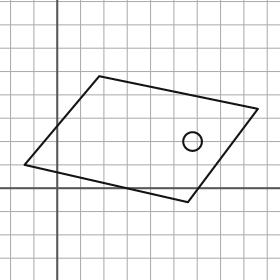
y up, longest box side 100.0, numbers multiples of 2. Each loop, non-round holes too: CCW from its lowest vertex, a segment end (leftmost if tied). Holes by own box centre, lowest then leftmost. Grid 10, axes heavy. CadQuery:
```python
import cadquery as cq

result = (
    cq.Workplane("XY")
    .moveTo(56.0, -6.0)
    .lineTo(86.0, 34.0)
    .lineTo(18.0, 48.0)
    .lineTo(-14.0, 10.0)
    .close()
    .moveTo(58.0, 20.0)
    .circle(4.0)
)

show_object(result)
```